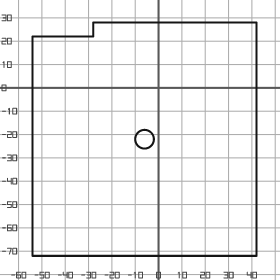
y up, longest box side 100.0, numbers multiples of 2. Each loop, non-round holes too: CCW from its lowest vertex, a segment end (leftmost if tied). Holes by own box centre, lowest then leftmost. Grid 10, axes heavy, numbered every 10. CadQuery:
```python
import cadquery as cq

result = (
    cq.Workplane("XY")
    .moveTo(-54.0, -72.0)
    .lineTo(42.0, -72.0)
    .lineTo(42.0, 28.0)
    .lineTo(-28.0, 28.0)
    .lineTo(-28.0, 22.0)
    .lineTo(-54.0, 22.0)
    .close()
    .moveTo(-6.0, -22.0)
    .circle(4.0)
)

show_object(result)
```